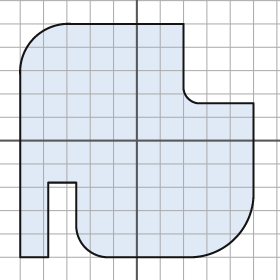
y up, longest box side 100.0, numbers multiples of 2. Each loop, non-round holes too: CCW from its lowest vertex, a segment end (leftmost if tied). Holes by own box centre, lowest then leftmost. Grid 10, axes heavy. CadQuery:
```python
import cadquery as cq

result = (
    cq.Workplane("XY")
    .moveTo(-50.0, -50.0)
    .lineTo(-38.0, -50.0)
    .lineTo(-38.0, -18.0)
    .lineTo(-26.0, -18.0)
    .lineTo(-26.0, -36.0)
    .threePointArc((-22.0, -46.0), (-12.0, -50.0))
    .lineTo(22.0, -50.0)
    .threePointArc((42.0, -42.0), (50.0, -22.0))
    .lineTo(50.0, 16.0)
    .lineTo(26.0, 16.0)
    .threePointArc((22.0, 18.0), (20.0, 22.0))
    .lineTo(20.0, 50.0)
    .lineTo(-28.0, 50.0)
    .threePointArc((-44.0, 44.0), (-50.0, 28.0))
    .close()
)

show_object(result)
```